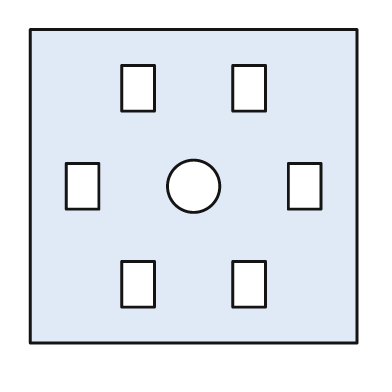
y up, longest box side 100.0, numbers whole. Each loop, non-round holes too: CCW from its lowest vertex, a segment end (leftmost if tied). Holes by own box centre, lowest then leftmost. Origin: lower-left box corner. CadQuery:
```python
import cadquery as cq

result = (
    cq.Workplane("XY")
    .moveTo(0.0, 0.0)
    .lineTo(100.0, 0.0)
    .lineTo(100.0, 96.0)
    .lineTo(0.0, 96.0)
    .close()
    .moveTo(28.0, 11.0)
    .lineTo(38.0, 11.0)
    .lineTo(38.0, 25.0)
    .lineTo(28.0, 25.0)
    .close()
    .moveTo(62.0, 11.0)
    .lineTo(72.0, 11.0)
    .lineTo(72.0, 25.0)
    .lineTo(62.0, 25.0)
    .close()
    .moveTo(11.0, 41.0)
    .lineTo(21.0, 41.0)
    .lineTo(21.0, 55.0)
    .lineTo(11.0, 55.0)
    .close()
    .moveTo(50.0, 48.0)
    .circle(8.0)
    .moveTo(79.0, 41.0)
    .lineTo(89.0, 41.0)
    .lineTo(89.0, 55.0)
    .lineTo(79.0, 55.0)
    .close()
    .moveTo(28.0, 71.0)
    .lineTo(38.0, 71.0)
    .lineTo(38.0, 85.0)
    .lineTo(28.0, 85.0)
    .close()
    .moveTo(62.0, 71.0)
    .lineTo(72.0, 71.0)
    .lineTo(72.0, 85.0)
    .lineTo(62.0, 85.0)
    .close()
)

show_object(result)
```